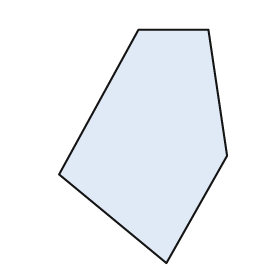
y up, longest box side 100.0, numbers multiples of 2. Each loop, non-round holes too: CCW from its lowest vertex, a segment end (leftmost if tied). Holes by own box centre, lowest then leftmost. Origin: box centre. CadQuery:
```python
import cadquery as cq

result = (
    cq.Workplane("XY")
    .moveTo(10.0, -50.0)
    .lineTo(36.0, -4.0)
    .lineTo(28.0, 50.0)
    .lineTo(-2.0, 50.0)
    .lineTo(-36.0, -12.0)
    .close()
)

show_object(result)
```